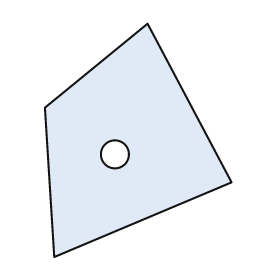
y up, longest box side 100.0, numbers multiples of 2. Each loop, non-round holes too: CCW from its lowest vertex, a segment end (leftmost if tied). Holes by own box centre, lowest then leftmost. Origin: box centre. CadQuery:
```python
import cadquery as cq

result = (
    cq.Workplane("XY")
    .moveTo(-36.0, -50.0)
    .lineTo(40.0, -18.0)
    .lineTo(4.0, 50.0)
    .lineTo(-40.0, 14.0)
    .close()
    .moveTo(-10.0, -6.0)
    .circle(6.0)
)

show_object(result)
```